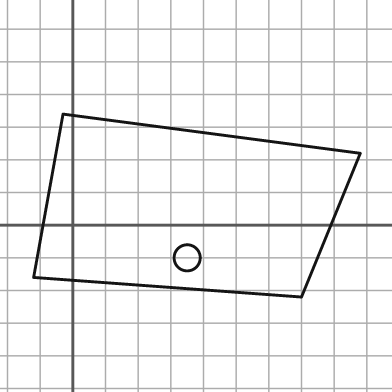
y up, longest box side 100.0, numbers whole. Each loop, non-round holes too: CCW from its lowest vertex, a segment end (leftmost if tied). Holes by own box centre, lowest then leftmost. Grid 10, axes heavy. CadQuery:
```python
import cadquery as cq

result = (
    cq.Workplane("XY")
    .moveTo(70.0, -22.0)
    .lineTo(88.0, 22.0)
    .lineTo(-3.0, 34.0)
    .lineTo(-12.0, -16.0)
    .close()
    .moveTo(35.0, -10.0)
    .circle(4.0)
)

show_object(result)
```